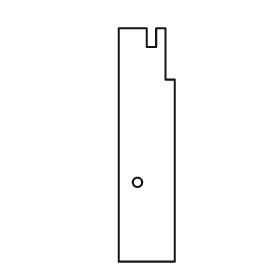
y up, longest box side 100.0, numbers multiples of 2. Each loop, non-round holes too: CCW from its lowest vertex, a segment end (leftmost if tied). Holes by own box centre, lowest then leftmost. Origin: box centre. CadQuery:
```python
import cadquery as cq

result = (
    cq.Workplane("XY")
    .moveTo(-12.0, -50.0)
    .lineTo(12.0, -50.0)
    .lineTo(12.0, 28.0)
    .lineTo(8.0, 28.0)
    .lineTo(8.0, 50.0)
    .lineTo(4.0, 50.0)
    .lineTo(4.0, 42.0)
    .lineTo(0.0, 42.0)
    .lineTo(0.0, 50.0)
    .lineTo(-12.0, 50.0)
    .close()
    .moveTo(-4.0, -16.0)
    .circle(2.0)
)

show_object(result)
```